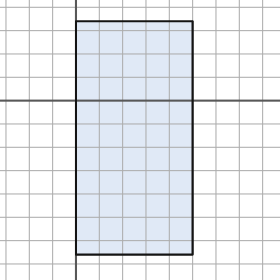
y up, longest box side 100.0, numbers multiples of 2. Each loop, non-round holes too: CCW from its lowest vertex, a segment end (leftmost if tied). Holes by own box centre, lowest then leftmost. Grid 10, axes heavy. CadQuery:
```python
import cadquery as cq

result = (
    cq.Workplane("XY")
    .moveTo(0.0, -66.0)
    .lineTo(50.0, -66.0)
    .lineTo(50.0, 34.0)
    .lineTo(0.0, 34.0)
    .close()
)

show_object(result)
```